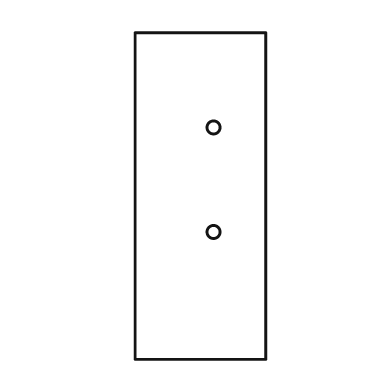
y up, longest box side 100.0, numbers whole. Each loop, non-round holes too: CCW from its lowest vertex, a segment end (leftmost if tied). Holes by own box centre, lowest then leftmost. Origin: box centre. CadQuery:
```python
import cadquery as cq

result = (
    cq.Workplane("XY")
    .moveTo(-20.0, -50.0)
    .lineTo(20.0, -50.0)
    .lineTo(20.0, 50.0)
    .lineTo(-20.0, 50.0)
    .close()
    .moveTo(4.0, -11.0)
    .circle(2.0)
    .moveTo(4.0, 21.0)
    .circle(2.0)
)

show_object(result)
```